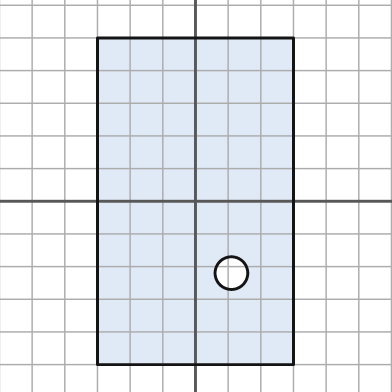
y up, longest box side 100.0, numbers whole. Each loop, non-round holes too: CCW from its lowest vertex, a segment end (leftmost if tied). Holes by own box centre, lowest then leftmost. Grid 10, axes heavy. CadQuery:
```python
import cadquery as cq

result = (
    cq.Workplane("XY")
    .moveTo(-30.0, -50.0)
    .lineTo(30.0, -50.0)
    .lineTo(30.0, 50.0)
    .lineTo(-30.0, 50.0)
    .close()
    .moveTo(11.0, -22.0)
    .circle(5.0)
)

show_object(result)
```